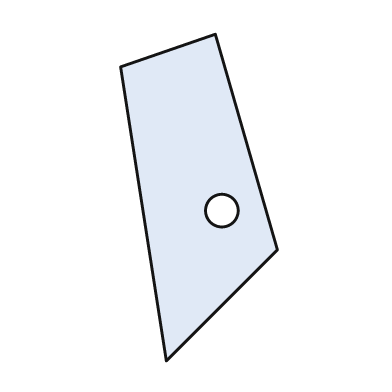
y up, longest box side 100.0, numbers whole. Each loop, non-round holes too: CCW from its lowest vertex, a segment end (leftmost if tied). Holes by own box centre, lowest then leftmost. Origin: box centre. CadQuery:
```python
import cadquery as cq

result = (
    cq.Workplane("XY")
    .moveTo(-10.0, -50.0)
    .lineTo(24.0, -16.0)
    .lineTo(5.0, 50.0)
    .lineTo(-24.0, 40.0)
    .close()
    .moveTo(7.0, -4.0)
    .circle(5.0)
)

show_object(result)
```